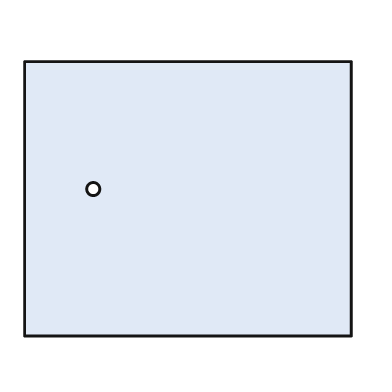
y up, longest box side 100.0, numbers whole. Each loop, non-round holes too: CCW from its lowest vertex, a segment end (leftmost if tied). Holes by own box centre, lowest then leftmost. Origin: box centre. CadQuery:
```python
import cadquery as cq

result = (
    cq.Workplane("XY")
    .moveTo(-50.0, -42.0)
    .lineTo(50.0, -42.0)
    .lineTo(50.0, 42.0)
    .lineTo(-50.0, 42.0)
    .close()
    .moveTo(-29.0, 3.0)
    .circle(2.0)
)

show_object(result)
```